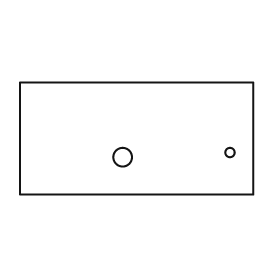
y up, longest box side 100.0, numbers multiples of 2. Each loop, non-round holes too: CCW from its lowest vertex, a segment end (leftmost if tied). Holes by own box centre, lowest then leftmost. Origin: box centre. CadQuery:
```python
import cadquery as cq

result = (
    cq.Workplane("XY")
    .moveTo(-50.0, -24.0)
    .lineTo(50.0, -24.0)
    .lineTo(50.0, 24.0)
    .lineTo(-50.0, 24.0)
    .close()
    .moveTo(-6.0, -8.0)
    .circle(4.0)
    .moveTo(40.0, -6.0)
    .circle(2.0)
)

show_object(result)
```